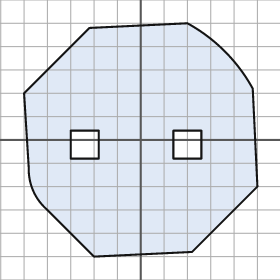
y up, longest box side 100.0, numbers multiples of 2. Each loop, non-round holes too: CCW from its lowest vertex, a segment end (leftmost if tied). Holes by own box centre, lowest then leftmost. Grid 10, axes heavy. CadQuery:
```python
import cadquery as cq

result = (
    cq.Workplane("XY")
    .moveTo(-20.0, -50.0)
    .lineTo(22.0, -48.0)
    .lineTo(50.0, -20.0)
    .lineTo(48.0, 22.0)
    .threePointArc((36.0, 38.0), (20.0, 50.0))
    .lineTo(-22.0, 48.0)
    .lineTo(-50.0, 20.0)
    .lineTo(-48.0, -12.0)
    .threePointArc((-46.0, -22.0), (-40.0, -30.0))
    .close()
    .moveTo(-30.0, -8.0)
    .lineTo(-18.0, -8.0)
    .lineTo(-18.0, 4.0)
    .lineTo(-30.0, 4.0)
    .close()
    .moveTo(14.0, -8.0)
    .lineTo(26.0, -8.0)
    .lineTo(26.0, 4.0)
    .lineTo(14.0, 4.0)
    .close()
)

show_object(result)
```